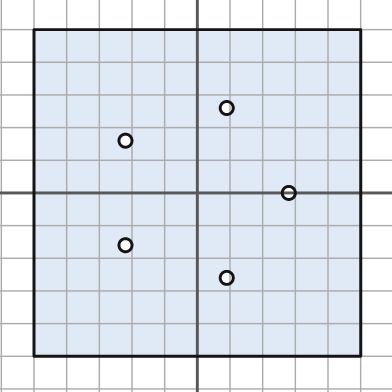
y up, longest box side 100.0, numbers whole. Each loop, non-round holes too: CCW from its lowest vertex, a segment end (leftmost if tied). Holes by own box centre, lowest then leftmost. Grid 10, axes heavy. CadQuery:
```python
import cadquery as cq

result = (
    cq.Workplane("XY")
    .moveTo(-50.0, -50.0)
    .lineTo(50.0, -50.0)
    .lineTo(50.0, 50.0)
    .lineTo(-50.0, 50.0)
    .close()
    .moveTo(9.0, -26.0)
    .circle(2.0)
    .moveTo(-22.0, -16.0)
    .circle(2.0)
    .moveTo(28.0, 0.0)
    .circle(2.0)
    .moveTo(-22.0, 16.0)
    .circle(2.0)
    .moveTo(9.0, 26.0)
    .circle(2.0)
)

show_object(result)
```